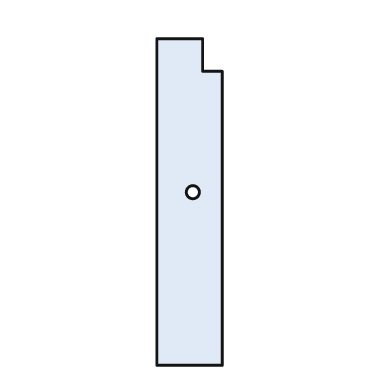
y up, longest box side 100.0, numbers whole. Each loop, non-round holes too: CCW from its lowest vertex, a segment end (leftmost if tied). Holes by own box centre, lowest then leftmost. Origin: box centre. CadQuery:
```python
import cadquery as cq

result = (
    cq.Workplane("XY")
    .moveTo(-10.0, -50.0)
    .lineTo(10.0, -50.0)
    .lineTo(10.0, 40.0)
    .lineTo(4.0, 40.0)
    .lineTo(4.0, 50.0)
    .lineTo(-10.0, 50.0)
    .close()
    .moveTo(1.0, 3.0)
    .circle(2.0)
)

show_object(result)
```